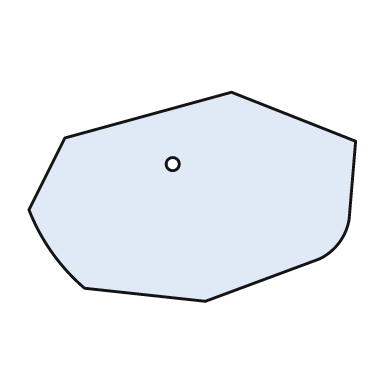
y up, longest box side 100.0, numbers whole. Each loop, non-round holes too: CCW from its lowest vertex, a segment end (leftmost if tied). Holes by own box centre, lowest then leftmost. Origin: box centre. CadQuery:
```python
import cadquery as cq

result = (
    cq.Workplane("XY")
    .moveTo(4.0, -32.0)
    .lineTo(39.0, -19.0)
    .threePointArc((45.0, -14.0), (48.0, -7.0))
    .lineTo(50.0, 17.0)
    .lineTo(12.0, 32.0)
    .lineTo(-39.0, 18.0)
    .lineTo(-50.0, -4.0)
    .threePointArc((-43.0, -17.0), (-33.0, -28.0))
    .close()
    .moveTo(-6.0, 10.0)
    .circle(2.0)
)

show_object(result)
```